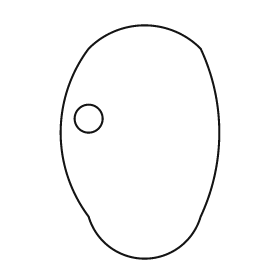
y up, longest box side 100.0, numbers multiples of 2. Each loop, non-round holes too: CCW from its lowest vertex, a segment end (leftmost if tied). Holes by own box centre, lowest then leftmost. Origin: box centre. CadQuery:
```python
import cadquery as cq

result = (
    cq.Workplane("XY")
    .moveTo(-22.0, -32.0)
    .threePointArc((2.0, -50.0), (26.0, -32.0))
    .threePointArc((34.0, 4.0), (26.0, 40.0))
    .threePointArc((2.0, 50.0), (-22.0, 40.0))
    .threePointArc((-34.0, 4.0), (-22.0, -32.0))
    .close()
    .moveTo(-22.0, 10.0)
    .circle(6.0)
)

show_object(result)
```